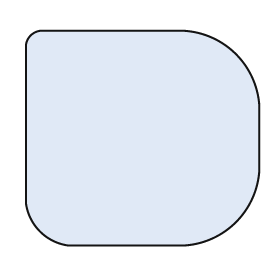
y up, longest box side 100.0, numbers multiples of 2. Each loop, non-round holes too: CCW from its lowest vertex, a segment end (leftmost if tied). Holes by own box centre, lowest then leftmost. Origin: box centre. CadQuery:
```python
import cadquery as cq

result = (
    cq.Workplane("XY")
    .moveTo(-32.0, -46.0)
    .lineTo(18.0, -46.0)
    .threePointArc((40.0, -36.0), (50.0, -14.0))
    .lineTo(50.0, 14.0)
    .threePointArc((40.0, 36.0), (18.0, 46.0))
    .lineTo(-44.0, 46.0)
    .threePointArc((-48.0, 44.0), (-50.0, 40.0))
    .lineTo(-50.0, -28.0)
    .threePointArc((-44.0, -40.0), (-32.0, -46.0))
    .close()
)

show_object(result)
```